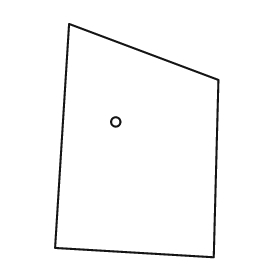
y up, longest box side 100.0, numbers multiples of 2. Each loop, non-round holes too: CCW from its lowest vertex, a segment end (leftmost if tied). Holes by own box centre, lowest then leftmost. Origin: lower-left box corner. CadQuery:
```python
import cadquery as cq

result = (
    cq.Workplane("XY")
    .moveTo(68.0, 0.0)
    .lineTo(70.0, 76.0)
    .lineTo(6.0, 100.0)
    .lineTo(0.0, 4.0)
    .close()
    .moveTo(26.0, 58.0)
    .circle(2.0)
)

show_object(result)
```